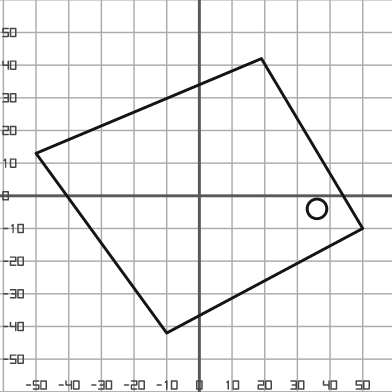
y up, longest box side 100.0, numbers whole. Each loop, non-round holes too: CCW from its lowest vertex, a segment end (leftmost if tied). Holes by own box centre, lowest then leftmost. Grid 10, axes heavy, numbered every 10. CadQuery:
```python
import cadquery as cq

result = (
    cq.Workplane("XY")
    .moveTo(-10.0, -42.0)
    .lineTo(50.0, -10.0)
    .lineTo(19.0, 42.0)
    .lineTo(-50.0, 13.0)
    .close()
    .moveTo(36.0, -4.0)
    .circle(3.0)
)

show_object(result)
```